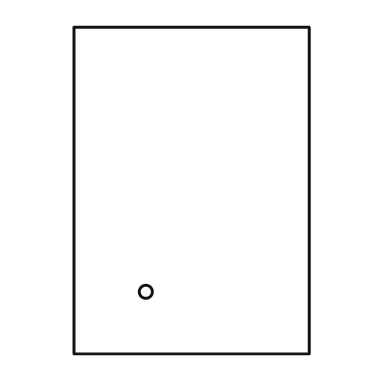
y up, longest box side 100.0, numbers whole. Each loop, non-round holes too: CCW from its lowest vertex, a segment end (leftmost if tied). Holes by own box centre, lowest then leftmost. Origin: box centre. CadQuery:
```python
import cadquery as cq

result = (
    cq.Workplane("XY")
    .moveTo(-36.0, -50.0)
    .lineTo(36.0, -50.0)
    .lineTo(36.0, 50.0)
    .lineTo(-36.0, 50.0)
    .close()
    .moveTo(-14.0, -31.0)
    .circle(2.0)
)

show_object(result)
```